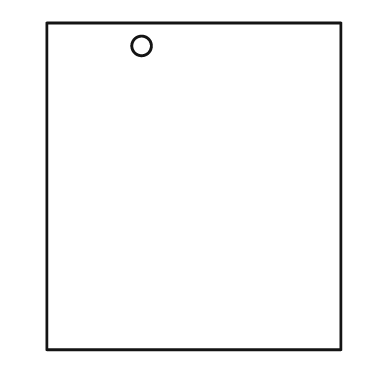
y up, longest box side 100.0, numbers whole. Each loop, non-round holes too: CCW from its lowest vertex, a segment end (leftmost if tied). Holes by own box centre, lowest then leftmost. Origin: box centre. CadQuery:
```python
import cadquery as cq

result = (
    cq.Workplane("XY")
    .moveTo(-45.0, -50.0)
    .lineTo(45.0, -50.0)
    .lineTo(45.0, 50.0)
    .lineTo(-45.0, 50.0)
    .close()
    .moveTo(-16.0, 43.0)
    .circle(3.0)
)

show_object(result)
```